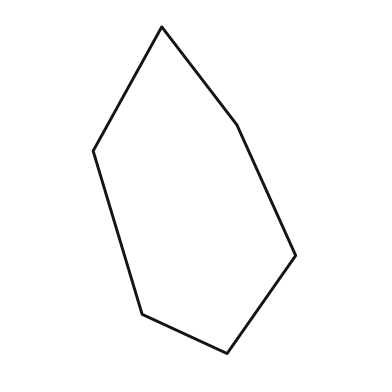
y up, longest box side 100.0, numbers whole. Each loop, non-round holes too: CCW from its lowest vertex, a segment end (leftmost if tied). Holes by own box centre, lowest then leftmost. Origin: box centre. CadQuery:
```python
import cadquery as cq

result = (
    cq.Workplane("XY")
    .moveTo(10.0, -50.0)
    .lineTo(31.0, -20.0)
    .lineTo(13.0, 20.0)
    .lineTo(-10.0, 50.0)
    .lineTo(-31.0, 12.0)
    .lineTo(-16.0, -38.0)
    .close()
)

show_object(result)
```